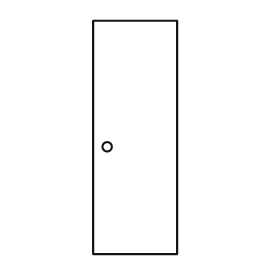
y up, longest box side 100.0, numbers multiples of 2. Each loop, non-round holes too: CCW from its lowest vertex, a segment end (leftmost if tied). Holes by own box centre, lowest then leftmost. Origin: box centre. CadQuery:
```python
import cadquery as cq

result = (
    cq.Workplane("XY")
    .moveTo(-18.0, -50.0)
    .lineTo(18.0, -50.0)
    .lineTo(18.0, 50.0)
    .lineTo(-18.0, 50.0)
    .close()
    .moveTo(-12.0, -4.0)
    .circle(2.0)
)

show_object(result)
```